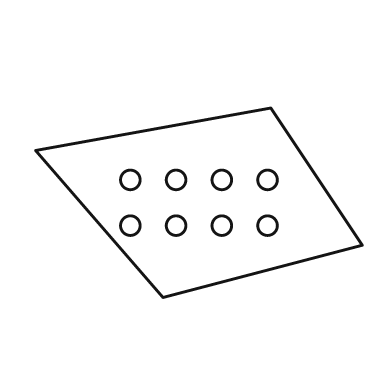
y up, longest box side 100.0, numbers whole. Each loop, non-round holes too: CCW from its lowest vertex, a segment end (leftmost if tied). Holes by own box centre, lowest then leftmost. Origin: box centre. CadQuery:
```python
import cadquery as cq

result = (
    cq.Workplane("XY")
    .moveTo(-11.0, -29.0)
    .lineTo(50.0, -13.0)
    .lineTo(22.0, 29.0)
    .lineTo(-50.0, 16.0)
    .close()
    .moveTo(-21.0, -7.0)
    .circle(3.0)
    .moveTo(-7.0, -7.0)
    .circle(3.0)
    .moveTo(7.0, -7.0)
    .circle(3.0)
    .moveTo(21.0, -7.0)
    .circle(3.0)
    .moveTo(-21.0, 7.0)
    .circle(3.0)
    .moveTo(-7.0, 7.0)
    .circle(3.0)
    .moveTo(7.0, 7.0)
    .circle(3.0)
    .moveTo(21.0, 7.0)
    .circle(3.0)
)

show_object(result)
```